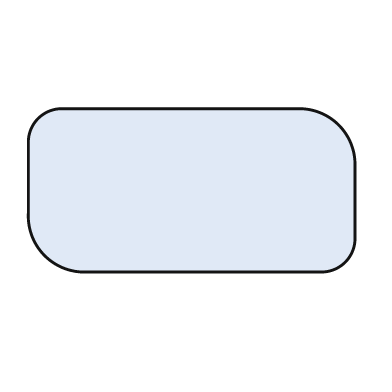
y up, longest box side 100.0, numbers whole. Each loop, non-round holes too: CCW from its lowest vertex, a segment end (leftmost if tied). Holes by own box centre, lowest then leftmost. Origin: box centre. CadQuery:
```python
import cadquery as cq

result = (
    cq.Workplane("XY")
    .moveTo(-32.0, -25.0)
    .lineTo(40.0, -25.0)
    .threePointArc((47.0, -22.0), (50.0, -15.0))
    .lineTo(50.0, 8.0)
    .threePointArc((45.0, 20.0), (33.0, 25.0))
    .lineTo(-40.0, 25.0)
    .threePointArc((-47.0, 22.0), (-50.0, 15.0))
    .lineTo(-50.0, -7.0)
    .threePointArc((-45.0, -20.0), (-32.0, -25.0))
    .close()
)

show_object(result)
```